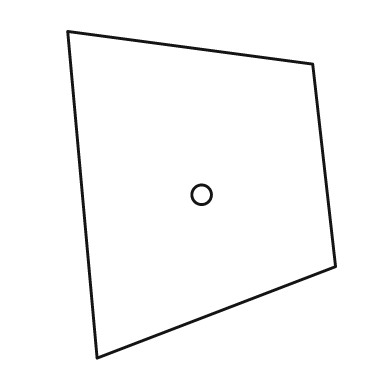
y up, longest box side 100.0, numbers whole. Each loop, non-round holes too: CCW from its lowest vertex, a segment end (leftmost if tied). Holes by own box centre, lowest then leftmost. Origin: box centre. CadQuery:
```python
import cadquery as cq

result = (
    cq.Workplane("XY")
    .moveTo(-32.0, -50.0)
    .lineTo(41.0, -22.0)
    .lineTo(34.0, 40.0)
    .lineTo(-41.0, 50.0)
    .close()
    .moveTo(0.0, 0.0)
    .circle(3.0)
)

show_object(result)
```